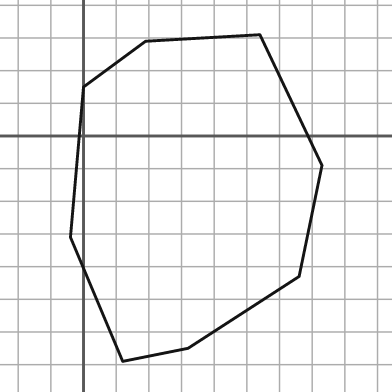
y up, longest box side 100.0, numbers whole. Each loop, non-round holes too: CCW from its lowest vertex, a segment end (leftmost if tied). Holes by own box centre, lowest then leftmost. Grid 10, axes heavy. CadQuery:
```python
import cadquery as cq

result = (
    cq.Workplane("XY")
    .moveTo(12.0, -69.0)
    .lineTo(32.0, -65.0)
    .lineTo(66.0, -43.0)
    .lineTo(73.0, -9.0)
    .lineTo(54.0, 31.0)
    .lineTo(19.0, 29.0)
    .lineTo(0.0, 15.0)
    .lineTo(-4.0, -31.0)
    .close()
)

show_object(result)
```